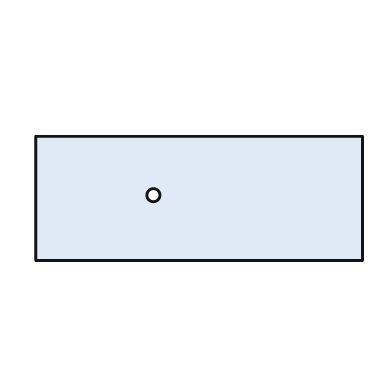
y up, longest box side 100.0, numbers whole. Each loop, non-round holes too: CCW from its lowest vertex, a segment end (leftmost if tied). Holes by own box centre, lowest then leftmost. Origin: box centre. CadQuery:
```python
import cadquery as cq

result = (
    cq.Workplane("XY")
    .moveTo(-50.0, -19.0)
    .lineTo(50.0, -19.0)
    .lineTo(50.0, 19.0)
    .lineTo(-50.0, 19.0)
    .close()
    .moveTo(-14.0, 1.0)
    .circle(2.0)
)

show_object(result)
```